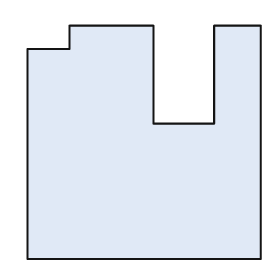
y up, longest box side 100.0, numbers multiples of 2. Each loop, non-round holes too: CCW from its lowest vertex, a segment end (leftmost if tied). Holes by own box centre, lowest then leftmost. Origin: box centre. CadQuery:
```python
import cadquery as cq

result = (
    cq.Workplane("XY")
    .moveTo(-50.0, -50.0)
    .lineTo(50.0, -50.0)
    .lineTo(50.0, 50.0)
    .lineTo(30.0, 50.0)
    .lineTo(30.0, 8.0)
    .lineTo(4.0, 8.0)
    .lineTo(4.0, 50.0)
    .lineTo(-32.0, 50.0)
    .lineTo(-32.0, 40.0)
    .lineTo(-50.0, 40.0)
    .close()
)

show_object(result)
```